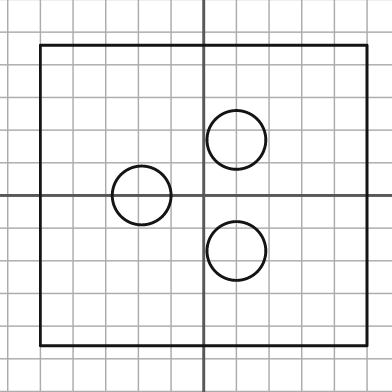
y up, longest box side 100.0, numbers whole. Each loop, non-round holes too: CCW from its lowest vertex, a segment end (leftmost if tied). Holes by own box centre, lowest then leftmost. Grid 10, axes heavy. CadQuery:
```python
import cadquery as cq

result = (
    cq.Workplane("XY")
    .moveTo(-50.0, -46.0)
    .lineTo(50.0, -46.0)
    .lineTo(50.0, 46.0)
    .lineTo(-50.0, 46.0)
    .close()
    .moveTo(10.0, -17.0)
    .circle(9.0)
    .moveTo(-19.0, 0.0)
    .circle(9.0)
    .moveTo(10.0, 17.0)
    .circle(9.0)
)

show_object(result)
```